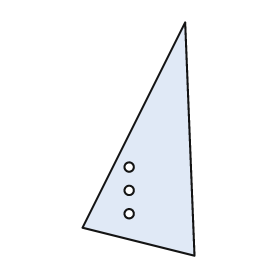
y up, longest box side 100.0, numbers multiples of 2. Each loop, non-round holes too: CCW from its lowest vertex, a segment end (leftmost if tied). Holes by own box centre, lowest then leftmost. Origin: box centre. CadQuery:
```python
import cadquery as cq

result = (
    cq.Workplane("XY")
    .moveTo(24.0, -50.0)
    .lineTo(20.0, 50.0)
    .lineTo(-24.0, -38.0)
    .close()
    .moveTo(-4.0, -32.0)
    .circle(2.0)
    .moveTo(-4.0, -22.0)
    .circle(2.0)
    .moveTo(-4.0, -12.0)
    .circle(2.0)
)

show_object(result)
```